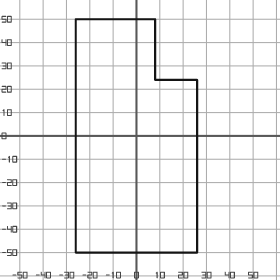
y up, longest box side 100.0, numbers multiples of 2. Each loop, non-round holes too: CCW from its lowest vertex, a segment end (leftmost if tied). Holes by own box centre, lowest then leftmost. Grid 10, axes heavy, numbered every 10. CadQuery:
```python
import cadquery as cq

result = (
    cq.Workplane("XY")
    .moveTo(-26.0, -50.0)
    .lineTo(26.0, -50.0)
    .lineTo(26.0, 24.0)
    .lineTo(8.0, 24.0)
    .lineTo(8.0, 50.0)
    .lineTo(-26.0, 50.0)
    .close()
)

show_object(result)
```